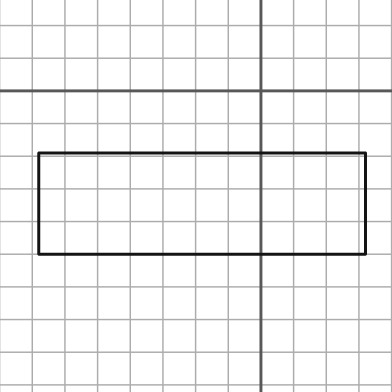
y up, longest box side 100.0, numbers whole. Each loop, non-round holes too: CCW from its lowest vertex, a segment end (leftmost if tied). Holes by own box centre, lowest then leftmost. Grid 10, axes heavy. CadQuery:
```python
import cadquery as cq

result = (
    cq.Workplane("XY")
    .moveTo(-68.0, -50.0)
    .lineTo(32.0, -50.0)
    .lineTo(32.0, -19.0)
    .lineTo(-68.0, -19.0)
    .close()
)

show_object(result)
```